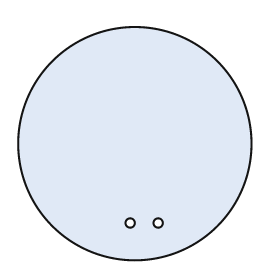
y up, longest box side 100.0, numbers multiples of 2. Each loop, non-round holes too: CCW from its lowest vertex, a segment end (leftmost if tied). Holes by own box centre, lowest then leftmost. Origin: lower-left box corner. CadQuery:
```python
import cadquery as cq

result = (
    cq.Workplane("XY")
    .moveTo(50.0, 50.0)
    .circle(50.0)
    .moveTo(48.0, 16.0)
    .circle(2.0)
    .moveTo(60.0, 16.0)
    .circle(2.0)
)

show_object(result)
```